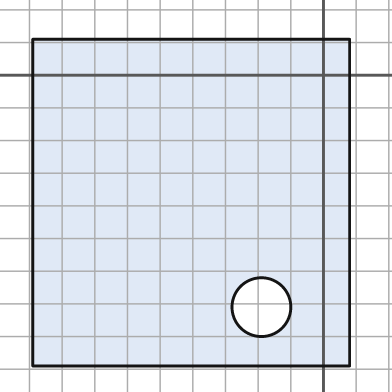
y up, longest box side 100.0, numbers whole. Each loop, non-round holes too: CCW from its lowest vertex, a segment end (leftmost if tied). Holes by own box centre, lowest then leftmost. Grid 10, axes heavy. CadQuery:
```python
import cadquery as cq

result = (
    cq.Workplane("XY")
    .moveTo(-89.0, -89.0)
    .lineTo(8.0, -89.0)
    .lineTo(8.0, 11.0)
    .lineTo(-89.0, 11.0)
    .close()
    .moveTo(-19.0, -71.0)
    .circle(9.0)
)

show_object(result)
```